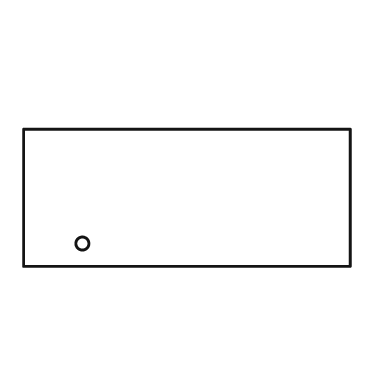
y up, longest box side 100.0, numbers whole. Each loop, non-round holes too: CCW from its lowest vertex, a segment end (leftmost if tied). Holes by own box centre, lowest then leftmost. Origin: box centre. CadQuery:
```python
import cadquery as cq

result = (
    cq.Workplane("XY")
    .moveTo(-50.0, -21.0)
    .lineTo(50.0, -21.0)
    .lineTo(50.0, 21.0)
    .lineTo(-50.0, 21.0)
    .close()
    .moveTo(-32.0, -14.0)
    .circle(2.0)
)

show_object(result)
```